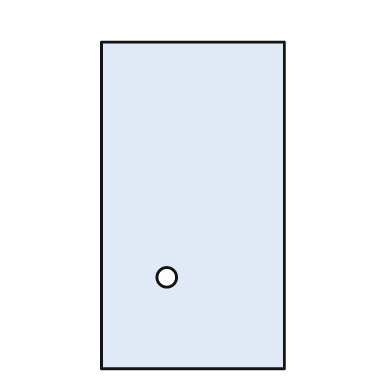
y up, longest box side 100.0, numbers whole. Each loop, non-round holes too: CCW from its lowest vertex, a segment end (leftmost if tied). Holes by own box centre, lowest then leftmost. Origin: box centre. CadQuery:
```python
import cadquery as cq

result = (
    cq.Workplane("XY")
    .moveTo(-28.0, -50.0)
    .lineTo(28.0, -50.0)
    .lineTo(28.0, 50.0)
    .lineTo(-28.0, 50.0)
    .close()
    .moveTo(-8.0, -22.0)
    .circle(3.0)
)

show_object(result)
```